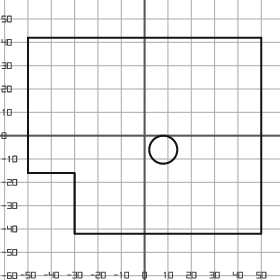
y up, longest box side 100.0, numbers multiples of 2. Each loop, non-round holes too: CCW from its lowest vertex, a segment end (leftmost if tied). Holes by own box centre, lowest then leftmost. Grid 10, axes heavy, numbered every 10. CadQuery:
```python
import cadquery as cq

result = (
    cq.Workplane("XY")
    .moveTo(-30.0, -42.0)
    .lineTo(50.0, -42.0)
    .lineTo(50.0, 42.0)
    .lineTo(-50.0, 42.0)
    .lineTo(-50.0, -16.0)
    .lineTo(-30.0, -16.0)
    .close()
    .moveTo(8.0, -6.0)
    .circle(6.0)
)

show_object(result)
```